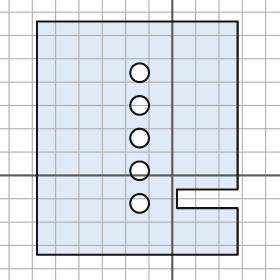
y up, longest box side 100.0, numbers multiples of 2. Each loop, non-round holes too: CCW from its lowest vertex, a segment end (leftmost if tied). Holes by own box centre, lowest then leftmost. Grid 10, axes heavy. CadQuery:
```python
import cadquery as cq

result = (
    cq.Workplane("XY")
    .moveTo(-58.0, -34.0)
    .lineTo(28.0, -34.0)
    .lineTo(28.0, -14.0)
    .lineTo(2.0, -14.0)
    .lineTo(2.0, -6.0)
    .lineTo(28.0, -6.0)
    .lineTo(28.0, 66.0)
    .lineTo(-58.0, 66.0)
    .close()
    .moveTo(-14.0, -12.0)
    .circle(4.0)
    .moveTo(-14.0, 2.0)
    .circle(4.0)
    .moveTo(-14.0, 16.0)
    .circle(4.0)
    .moveTo(-14.0, 30.0)
    .circle(4.0)
    .moveTo(-14.0, 44.0)
    .circle(4.0)
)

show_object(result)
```